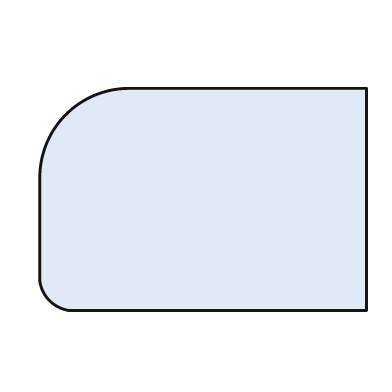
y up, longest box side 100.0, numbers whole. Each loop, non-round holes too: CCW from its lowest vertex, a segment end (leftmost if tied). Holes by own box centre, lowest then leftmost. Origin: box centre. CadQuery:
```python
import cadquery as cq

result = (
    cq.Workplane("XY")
    .moveTo(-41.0, -34.0)
    .lineTo(50.0, -34.0)
    .lineTo(50.0, 34.0)
    .lineTo(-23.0, 34.0)
    .threePointArc((-42.0, 26.0), (-50.0, 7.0))
    .lineTo(-50.0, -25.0)
    .threePointArc((-47.0, -31.0), (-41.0, -34.0))
    .close()
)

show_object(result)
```